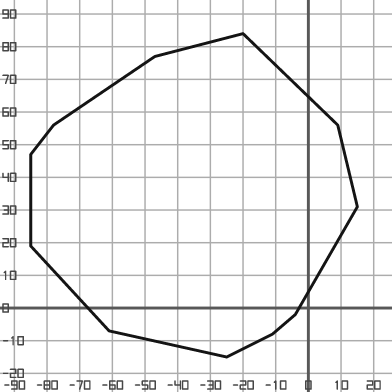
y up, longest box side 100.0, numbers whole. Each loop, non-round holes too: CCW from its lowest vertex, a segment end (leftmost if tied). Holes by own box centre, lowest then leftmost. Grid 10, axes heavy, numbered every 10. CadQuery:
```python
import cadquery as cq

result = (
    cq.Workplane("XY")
    .moveTo(-25.0, -15.0)
    .lineTo(-11.0, -8.0)
    .lineTo(-4.0, -2.0)
    .lineTo(15.0, 31.0)
    .lineTo(9.0, 56.0)
    .lineTo(-20.0, 84.0)
    .lineTo(-47.0, 77.0)
    .lineTo(-78.0, 56.0)
    .lineTo(-85.0, 47.0)
    .lineTo(-85.0, 19.0)
    .lineTo(-61.0, -7.0)
    .close()
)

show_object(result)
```